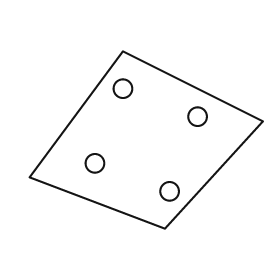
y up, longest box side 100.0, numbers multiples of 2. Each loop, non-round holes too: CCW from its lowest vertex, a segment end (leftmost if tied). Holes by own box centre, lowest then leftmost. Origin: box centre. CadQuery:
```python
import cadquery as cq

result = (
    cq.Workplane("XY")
    .moveTo(8.0, -38.0)
    .lineTo(50.0, 8.0)
    .lineTo(-10.0, 38.0)
    .lineTo(-50.0, -16.0)
    .close()
    .moveTo(10.0, -22.0)
    .circle(4.0)
    .moveTo(-22.0, -10.0)
    .circle(4.0)
    .moveTo(22.0, 10.0)
    .circle(4.0)
    .moveTo(-10.0, 22.0)
    .circle(4.0)
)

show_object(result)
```